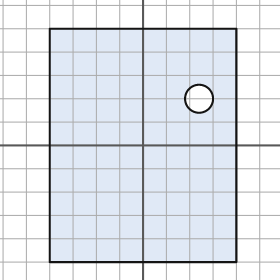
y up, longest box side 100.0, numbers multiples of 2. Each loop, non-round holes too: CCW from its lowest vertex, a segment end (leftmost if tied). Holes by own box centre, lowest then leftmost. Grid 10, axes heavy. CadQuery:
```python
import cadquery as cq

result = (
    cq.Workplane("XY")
    .moveTo(-40.0, -50.0)
    .lineTo(40.0, -50.0)
    .lineTo(40.0, 50.0)
    .lineTo(-40.0, 50.0)
    .close()
    .moveTo(24.0, 20.0)
    .circle(6.0)
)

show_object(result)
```